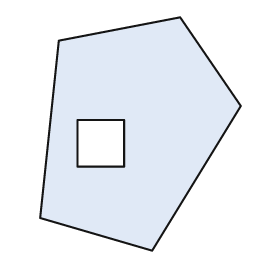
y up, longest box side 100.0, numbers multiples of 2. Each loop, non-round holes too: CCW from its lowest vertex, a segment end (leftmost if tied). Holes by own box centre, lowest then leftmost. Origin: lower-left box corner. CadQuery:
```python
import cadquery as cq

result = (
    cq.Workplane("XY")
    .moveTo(48.0, 0.0)
    .lineTo(86.0, 62.0)
    .lineTo(60.0, 100.0)
    .lineTo(8.0, 90.0)
    .lineTo(0.0, 14.0)
    .close()
    .moveTo(16.0, 36.0)
    .lineTo(36.0, 36.0)
    .lineTo(36.0, 56.0)
    .lineTo(16.0, 56.0)
    .close()
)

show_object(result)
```